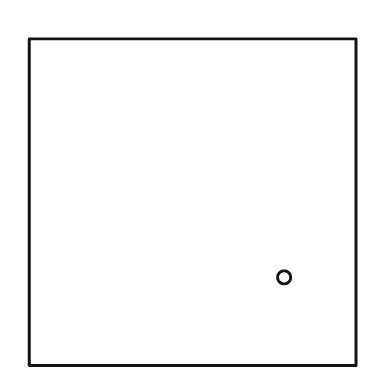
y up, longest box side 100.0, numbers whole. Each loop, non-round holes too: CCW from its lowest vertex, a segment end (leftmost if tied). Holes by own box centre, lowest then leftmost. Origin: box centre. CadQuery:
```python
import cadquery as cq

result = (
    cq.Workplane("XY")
    .moveTo(-50.0, -50.0)
    .lineTo(50.0, -50.0)
    .lineTo(50.0, 50.0)
    .lineTo(-50.0, 50.0)
    .close()
    .moveTo(28.0, -23.0)
    .circle(2.0)
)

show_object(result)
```